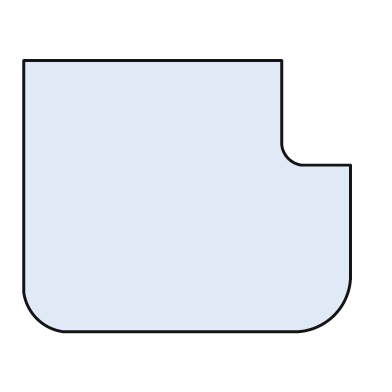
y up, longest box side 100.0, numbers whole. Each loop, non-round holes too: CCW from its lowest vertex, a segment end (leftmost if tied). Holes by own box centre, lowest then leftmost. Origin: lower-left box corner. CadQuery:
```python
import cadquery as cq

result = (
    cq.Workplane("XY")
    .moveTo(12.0, 0.0)
    .lineTo(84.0, 0.0)
    .threePointArc((95.0, 5.0), (100.0, 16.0))
    .lineTo(100.0, 51.0)
    .lineTo(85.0, 51.0)
    .threePointArc((81.0, 53.0), (79.0, 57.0))
    .lineTo(79.0, 83.0)
    .lineTo(0.0, 83.0)
    .lineTo(0.0, 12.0)
    .threePointArc((4.0, 4.0), (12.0, 0.0))
    .close()
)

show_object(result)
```